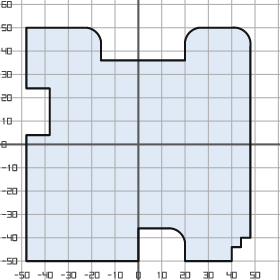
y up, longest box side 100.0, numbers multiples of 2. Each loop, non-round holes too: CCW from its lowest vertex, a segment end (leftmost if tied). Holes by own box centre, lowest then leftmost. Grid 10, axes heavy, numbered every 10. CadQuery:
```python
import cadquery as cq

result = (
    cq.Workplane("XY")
    .moveTo(-48.0, -50.0)
    .lineTo(0.0, -50.0)
    .lineTo(0.0, -36.0)
    .lineTo(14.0, -36.0)
    .threePointArc((18.0, -38.0), (20.0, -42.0))
    .lineTo(20.0, -50.0)
    .lineTo(40.0, -50.0)
    .lineTo(40.0, -44.0)
    .lineTo(44.0, -44.0)
    .lineTo(44.0, -40.0)
    .lineTo(48.0, -40.0)
    .lineTo(48.0, 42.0)
    .threePointArc((46.0, 48.0), (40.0, 50.0))
    .lineTo(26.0, 50.0)
    .threePointArc((22.0, 48.0), (20.0, 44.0))
    .lineTo(20.0, 36.0)
    .lineTo(-16.0, 36.0)
    .lineTo(-16.0, 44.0)
    .threePointArc((-18.0, 48.0), (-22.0, 50.0))
    .lineTo(-48.0, 50.0)
    .lineTo(-48.0, 24.0)
    .lineTo(-38.0, 24.0)
    .lineTo(-38.0, 4.0)
    .lineTo(-48.0, 4.0)
    .close()
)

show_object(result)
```